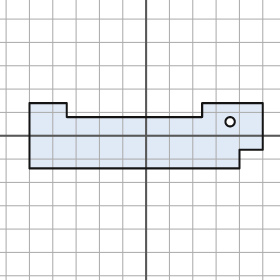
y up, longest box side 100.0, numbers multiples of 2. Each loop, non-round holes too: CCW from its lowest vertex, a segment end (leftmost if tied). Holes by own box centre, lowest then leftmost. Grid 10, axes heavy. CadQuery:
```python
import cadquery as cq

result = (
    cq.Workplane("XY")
    .moveTo(-50.0, -14.0)
    .lineTo(40.0, -14.0)
    .lineTo(40.0, -6.0)
    .lineTo(50.0, -6.0)
    .lineTo(50.0, 14.0)
    .lineTo(24.0, 14.0)
    .lineTo(24.0, 8.0)
    .lineTo(-34.0, 8.0)
    .lineTo(-34.0, 14.0)
    .lineTo(-50.0, 14.0)
    .close()
    .moveTo(36.0, 6.0)
    .circle(2.0)
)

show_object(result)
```